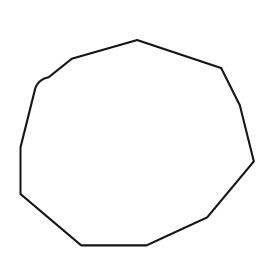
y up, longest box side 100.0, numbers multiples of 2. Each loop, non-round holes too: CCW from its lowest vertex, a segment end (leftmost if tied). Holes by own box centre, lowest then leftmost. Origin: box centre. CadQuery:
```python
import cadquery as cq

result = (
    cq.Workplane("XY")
    .moveTo(-24.0, -44.0)
    .lineTo(4.0, -44.0)
    .lineTo(30.0, -32.0)
    .lineTo(50.0, -8.0)
    .lineTo(44.0, 16.0)
    .lineTo(36.0, 32.0)
    .lineTo(0.0, 44.0)
    .lineTo(-28.0, 36.0)
    .lineTo(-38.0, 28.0)
    .threePointArc((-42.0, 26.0), (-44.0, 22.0))
    .lineTo(-50.0, -2.0)
    .lineTo(-50.0, -22.0)
    .close()
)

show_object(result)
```